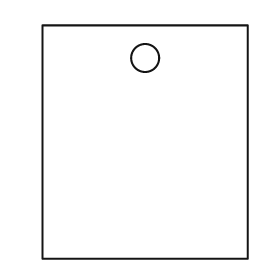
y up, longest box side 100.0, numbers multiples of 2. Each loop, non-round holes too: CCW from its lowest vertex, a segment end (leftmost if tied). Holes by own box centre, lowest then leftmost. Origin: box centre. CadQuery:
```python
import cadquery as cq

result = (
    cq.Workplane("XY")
    .moveTo(-44.0, -50.0)
    .lineTo(44.0, -50.0)
    .lineTo(44.0, 50.0)
    .lineTo(-44.0, 50.0)
    .close()
    .moveTo(0.0, 36.0)
    .circle(6.0)
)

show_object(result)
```